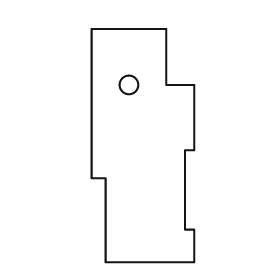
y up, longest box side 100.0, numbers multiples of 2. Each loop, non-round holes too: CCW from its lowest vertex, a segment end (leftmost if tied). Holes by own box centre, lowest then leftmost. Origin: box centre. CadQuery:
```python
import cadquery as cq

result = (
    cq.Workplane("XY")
    .moveTo(-16.0, -50.0)
    .lineTo(22.0, -50.0)
    .lineTo(22.0, -36.0)
    .lineTo(18.0, -36.0)
    .lineTo(18.0, -2.0)
    .lineTo(22.0, -2.0)
    .lineTo(22.0, 26.0)
    .lineTo(10.0, 26.0)
    .lineTo(10.0, 50.0)
    .lineTo(-22.0, 50.0)
    .lineTo(-22.0, -14.0)
    .lineTo(-16.0, -14.0)
    .close()
    .moveTo(-6.0, 26.0)
    .circle(4.0)
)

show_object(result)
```